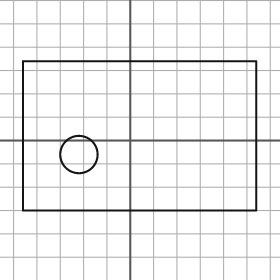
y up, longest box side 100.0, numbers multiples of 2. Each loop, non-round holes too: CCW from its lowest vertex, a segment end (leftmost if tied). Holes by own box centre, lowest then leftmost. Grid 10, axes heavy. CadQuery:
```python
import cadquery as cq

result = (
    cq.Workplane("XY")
    .moveTo(-46.0, -30.0)
    .lineTo(54.0, -30.0)
    .lineTo(54.0, 34.0)
    .lineTo(-46.0, 34.0)
    .close()
    .moveTo(-22.0, -6.0)
    .circle(8.0)
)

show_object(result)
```